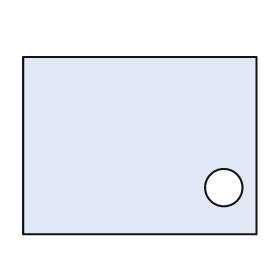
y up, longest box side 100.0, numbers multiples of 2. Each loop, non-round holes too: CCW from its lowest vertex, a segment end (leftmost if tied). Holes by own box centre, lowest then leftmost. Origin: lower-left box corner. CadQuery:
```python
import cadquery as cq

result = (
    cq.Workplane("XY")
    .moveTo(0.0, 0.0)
    .lineTo(100.0, 0.0)
    .lineTo(100.0, 76.0)
    .lineTo(0.0, 76.0)
    .close()
    .moveTo(86.0, 20.0)
    .circle(8.0)
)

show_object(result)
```